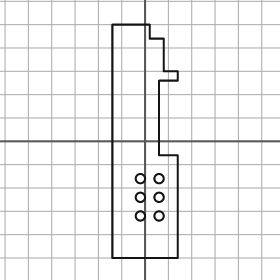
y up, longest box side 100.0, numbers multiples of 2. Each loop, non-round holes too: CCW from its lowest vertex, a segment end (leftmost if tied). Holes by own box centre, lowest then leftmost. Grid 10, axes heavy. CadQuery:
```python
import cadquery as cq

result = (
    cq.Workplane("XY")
    .moveTo(-14.0, -50.0)
    .lineTo(14.0, -50.0)
    .lineTo(14.0, -6.0)
    .lineTo(6.0, -6.0)
    .lineTo(6.0, 26.0)
    .lineTo(14.0, 26.0)
    .lineTo(14.0, 30.0)
    .lineTo(8.0, 30.0)
    .lineTo(8.0, 44.0)
    .lineTo(2.0, 44.0)
    .lineTo(2.0, 50.0)
    .lineTo(-14.0, 50.0)
    .close()
    .moveTo(-2.0, -32.0)
    .circle(2.0)
    .moveTo(6.0, -32.0)
    .circle(2.0)
    .moveTo(-2.0, -24.0)
    .circle(2.0)
    .moveTo(6.0, -24.0)
    .circle(2.0)
    .moveTo(-2.0, -16.0)
    .circle(2.0)
    .moveTo(6.0, -16.0)
    .circle(2.0)
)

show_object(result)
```